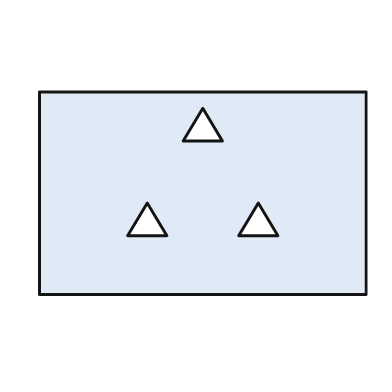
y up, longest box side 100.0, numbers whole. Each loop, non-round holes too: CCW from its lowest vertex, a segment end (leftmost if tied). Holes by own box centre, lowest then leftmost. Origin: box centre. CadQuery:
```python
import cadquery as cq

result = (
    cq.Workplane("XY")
    .moveTo(-50.0, -31.0)
    .lineTo(50.0, -31.0)
    .lineTo(50.0, 31.0)
    .lineTo(-50.0, 31.0)
    .close()
    .moveTo(-23.0, -13.0)
    .lineTo(-11.0, -13.0)
    .lineTo(-17.0, -3.0)
    .close()
    .moveTo(11.0, -13.0)
    .lineTo(23.0, -13.0)
    .lineTo(17.0, -3.0)
    .close()
    .moveTo(-6.0, 16.0)
    .lineTo(6.0, 16.0)
    .lineTo(0.0, 26.0)
    .close()
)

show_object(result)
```